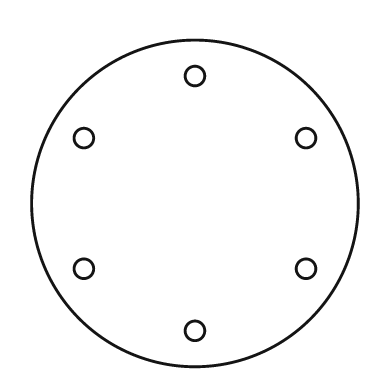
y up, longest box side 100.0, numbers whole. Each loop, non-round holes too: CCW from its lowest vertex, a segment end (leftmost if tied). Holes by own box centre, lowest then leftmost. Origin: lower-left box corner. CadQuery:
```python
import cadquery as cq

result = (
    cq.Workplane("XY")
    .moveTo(50.0, 50.0)
    .circle(50.0)
    .moveTo(50.0, 11.0)
    .circle(3.0)
    .moveTo(16.0, 30.0)
    .circle(3.0)
    .moveTo(84.0, 30.0)
    .circle(3.0)
    .moveTo(16.0, 70.0)
    .circle(3.0)
    .moveTo(84.0, 70.0)
    .circle(3.0)
    .moveTo(50.0, 89.0)
    .circle(3.0)
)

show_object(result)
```